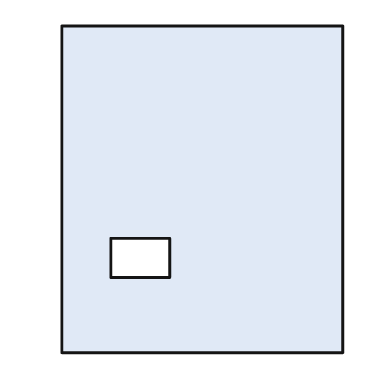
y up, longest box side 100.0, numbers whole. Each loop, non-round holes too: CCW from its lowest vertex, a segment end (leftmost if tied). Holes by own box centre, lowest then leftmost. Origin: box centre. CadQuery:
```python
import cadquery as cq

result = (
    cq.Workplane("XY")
    .moveTo(-43.0, -50.0)
    .lineTo(43.0, -50.0)
    .lineTo(43.0, 50.0)
    .lineTo(-43.0, 50.0)
    .close()
    .moveTo(-28.0, -27.0)
    .lineTo(-10.0, -27.0)
    .lineTo(-10.0, -15.0)
    .lineTo(-28.0, -15.0)
    .close()
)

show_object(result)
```